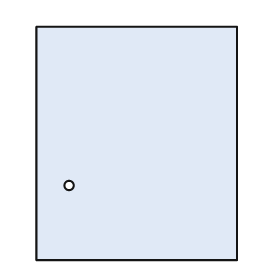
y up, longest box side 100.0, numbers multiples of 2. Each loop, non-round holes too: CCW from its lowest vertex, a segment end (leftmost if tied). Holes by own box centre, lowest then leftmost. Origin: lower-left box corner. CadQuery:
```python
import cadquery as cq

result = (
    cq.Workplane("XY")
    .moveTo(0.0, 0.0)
    .lineTo(86.0, 0.0)
    .lineTo(86.0, 100.0)
    .lineTo(0.0, 100.0)
    .close()
    .moveTo(14.0, 32.0)
    .circle(2.0)
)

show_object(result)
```